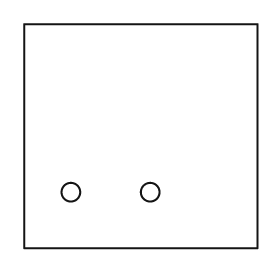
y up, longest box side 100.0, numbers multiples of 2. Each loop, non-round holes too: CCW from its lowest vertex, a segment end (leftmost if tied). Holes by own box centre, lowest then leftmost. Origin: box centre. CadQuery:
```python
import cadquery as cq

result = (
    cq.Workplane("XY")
    .moveTo(-50.0, -48.0)
    .lineTo(50.0, -48.0)
    .lineTo(50.0, 48.0)
    .lineTo(-50.0, 48.0)
    .close()
    .moveTo(-30.0, -24.0)
    .circle(4.0)
    .moveTo(4.0, -24.0)
    .circle(4.0)
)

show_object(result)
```